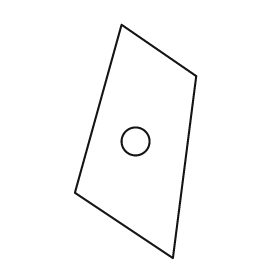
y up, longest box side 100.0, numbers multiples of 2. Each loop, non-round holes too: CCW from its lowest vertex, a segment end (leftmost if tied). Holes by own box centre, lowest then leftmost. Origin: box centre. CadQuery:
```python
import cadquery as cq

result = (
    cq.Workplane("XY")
    .moveTo(16.0, -50.0)
    .lineTo(26.0, 28.0)
    .lineTo(-6.0, 50.0)
    .lineTo(-26.0, -22.0)
    .close()
    .moveTo(0.0, 0.0)
    .circle(6.0)
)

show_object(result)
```